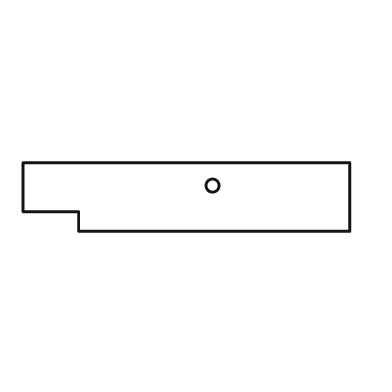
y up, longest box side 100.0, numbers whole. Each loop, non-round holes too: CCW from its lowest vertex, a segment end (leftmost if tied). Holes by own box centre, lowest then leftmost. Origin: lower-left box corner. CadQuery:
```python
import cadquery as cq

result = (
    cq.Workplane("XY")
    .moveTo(17.0, 0.0)
    .lineTo(100.0, 0.0)
    .lineTo(100.0, 21.0)
    .lineTo(0.0, 21.0)
    .lineTo(0.0, 6.0)
    .lineTo(17.0, 6.0)
    .close()
    .moveTo(58.0, 14.0)
    .circle(2.0)
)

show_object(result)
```